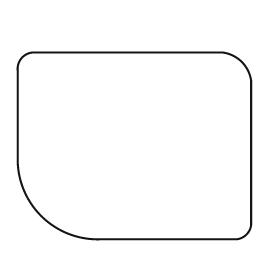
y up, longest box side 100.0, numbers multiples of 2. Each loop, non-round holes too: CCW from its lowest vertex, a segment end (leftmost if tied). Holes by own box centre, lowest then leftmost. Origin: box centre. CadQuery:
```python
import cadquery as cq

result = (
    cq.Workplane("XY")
    .moveTo(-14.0, -40.0)
    .lineTo(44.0, -40.0)
    .threePointArc((48.0, -38.0), (50.0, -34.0))
    .lineTo(50.0, 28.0)
    .threePointArc((46.0, 36.0), (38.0, 40.0))
    .lineTo(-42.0, 40.0)
    .threePointArc((-48.0, 38.0), (-50.0, 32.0))
    .lineTo(-50.0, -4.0)
    .threePointArc((-40.0, -30.0), (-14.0, -40.0))
    .close()
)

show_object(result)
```